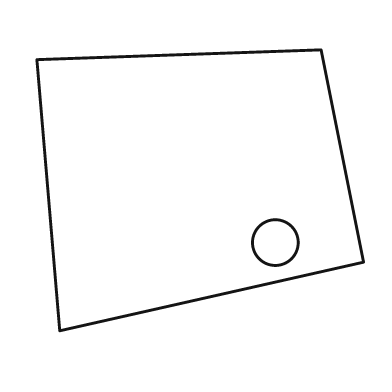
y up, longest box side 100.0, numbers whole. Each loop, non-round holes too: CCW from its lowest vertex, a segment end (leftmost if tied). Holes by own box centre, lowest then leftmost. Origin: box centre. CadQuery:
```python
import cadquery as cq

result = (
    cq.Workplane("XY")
    .moveTo(-43.0, -43.0)
    .lineTo(50.0, -22.0)
    .lineTo(37.0, 43.0)
    .lineTo(-50.0, 40.0)
    .close()
    .moveTo(23.0, -16.0)
    .circle(7.0)
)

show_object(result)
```